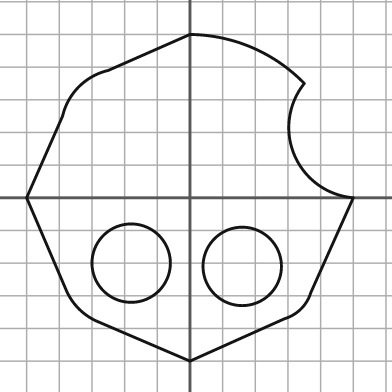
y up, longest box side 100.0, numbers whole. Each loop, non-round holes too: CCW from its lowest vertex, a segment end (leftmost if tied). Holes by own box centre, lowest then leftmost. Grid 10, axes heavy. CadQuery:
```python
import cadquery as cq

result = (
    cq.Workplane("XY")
    .moveTo(0.0, -50.0)
    .lineTo(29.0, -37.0)
    .threePointArc((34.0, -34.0), (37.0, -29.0))
    .lineTo(50.0, 0.0)
    .threePointArc((32.0, 13.0), (35.0, 35.0))
    .threePointArc((19.0, 46.0), (0.0, 50.0))
    .lineTo(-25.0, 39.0)
    .threePointArc((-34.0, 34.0), (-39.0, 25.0))
    .lineTo(-50.0, 0.0)
    .lineTo(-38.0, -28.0)
    .threePointArc((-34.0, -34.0), (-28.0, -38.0))
    .close()
    .moveTo(16.0, -21.0)
    .circle(12.0)
    .moveTo(-18.0, -20.0)
    .circle(12.0)
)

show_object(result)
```